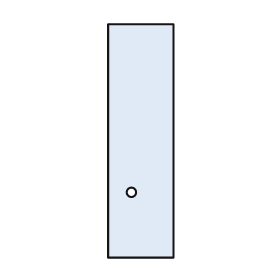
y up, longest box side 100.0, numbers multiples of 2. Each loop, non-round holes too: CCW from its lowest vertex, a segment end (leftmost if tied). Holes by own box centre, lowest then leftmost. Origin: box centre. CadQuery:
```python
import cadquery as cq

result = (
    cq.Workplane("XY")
    .moveTo(-14.0, -50.0)
    .lineTo(14.0, -50.0)
    .lineTo(14.0, 50.0)
    .lineTo(-14.0, 50.0)
    .close()
    .moveTo(-4.0, -22.0)
    .circle(2.0)
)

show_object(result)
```